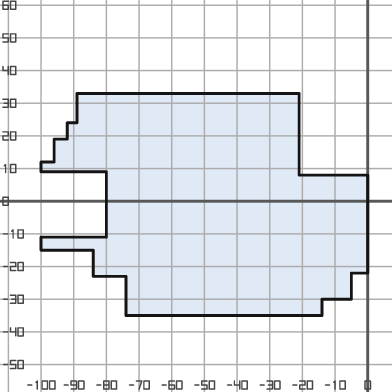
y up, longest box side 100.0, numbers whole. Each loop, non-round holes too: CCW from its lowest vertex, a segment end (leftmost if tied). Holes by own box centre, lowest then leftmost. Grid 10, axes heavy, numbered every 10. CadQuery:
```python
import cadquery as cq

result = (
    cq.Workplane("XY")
    .moveTo(-74.0, -35.0)
    .lineTo(-14.0, -35.0)
    .lineTo(-14.0, -30.0)
    .lineTo(-5.0, -30.0)
    .lineTo(-5.0, -22.0)
    .lineTo(0.0, -22.0)
    .lineTo(0.0, 8.0)
    .lineTo(-21.0, 8.0)
    .lineTo(-21.0, 33.0)
    .lineTo(-89.0, 33.0)
    .lineTo(-89.0, 24.0)
    .lineTo(-92.0, 24.0)
    .lineTo(-92.0, 19.0)
    .lineTo(-96.0, 19.0)
    .lineTo(-96.0, 12.0)
    .lineTo(-100.0, 12.0)
    .lineTo(-100.0, 9.0)
    .lineTo(-80.0, 9.0)
    .lineTo(-80.0, -11.0)
    .lineTo(-100.0, -11.0)
    .lineTo(-100.0, -15.0)
    .lineTo(-84.0, -15.0)
    .lineTo(-84.0, -23.0)
    .lineTo(-74.0, -23.0)
    .close()
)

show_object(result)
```